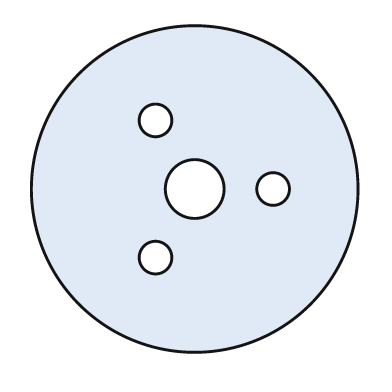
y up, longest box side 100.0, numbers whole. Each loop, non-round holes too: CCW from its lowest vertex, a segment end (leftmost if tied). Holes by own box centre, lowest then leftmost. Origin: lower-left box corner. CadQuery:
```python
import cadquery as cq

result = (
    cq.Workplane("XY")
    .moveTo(50.0, 50.0)
    .circle(50.0)
    .moveTo(38.0, 29.0)
    .circle(5.0)
    .moveTo(50.0, 50.0)
    .circle(9.0)
    .moveTo(74.0, 50.0)
    .circle(5.0)
    .moveTo(38.0, 71.0)
    .circle(5.0)
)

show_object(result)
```